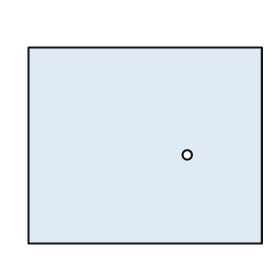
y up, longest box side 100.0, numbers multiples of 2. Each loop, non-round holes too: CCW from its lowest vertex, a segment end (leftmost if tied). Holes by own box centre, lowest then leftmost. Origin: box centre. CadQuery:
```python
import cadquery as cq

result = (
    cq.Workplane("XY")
    .moveTo(-50.0, -42.0)
    .lineTo(50.0, -42.0)
    .lineTo(50.0, 42.0)
    .lineTo(-50.0, 42.0)
    .close()
    .moveTo(18.0, -4.0)
    .circle(2.0)
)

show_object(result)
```